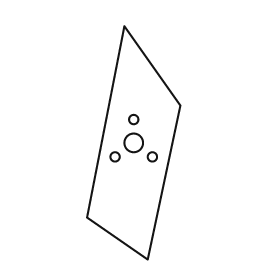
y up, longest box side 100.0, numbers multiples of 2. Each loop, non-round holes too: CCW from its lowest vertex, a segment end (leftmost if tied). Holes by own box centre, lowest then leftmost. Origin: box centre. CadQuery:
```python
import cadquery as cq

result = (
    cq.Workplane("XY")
    .moveTo(6.0, -50.0)
    .lineTo(20.0, 16.0)
    .lineTo(-4.0, 50.0)
    .lineTo(-20.0, -32.0)
    .close()
    .moveTo(-8.0, -6.0)
    .circle(2.0)
    .moveTo(8.0, -6.0)
    .circle(2.0)
    .moveTo(0.0, 0.0)
    .circle(4.0)
    .moveTo(0.0, 10.0)
    .circle(2.0)
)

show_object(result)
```